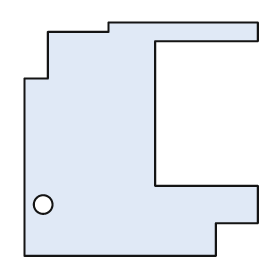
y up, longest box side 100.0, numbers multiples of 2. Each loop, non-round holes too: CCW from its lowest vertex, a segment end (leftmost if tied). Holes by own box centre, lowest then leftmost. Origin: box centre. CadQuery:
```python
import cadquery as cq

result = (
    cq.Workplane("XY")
    .moveTo(-50.0, -50.0)
    .lineTo(32.0, -50.0)
    .lineTo(32.0, -36.0)
    .lineTo(50.0, -36.0)
    .lineTo(50.0, -20.0)
    .lineTo(6.0, -20.0)
    .lineTo(6.0, 42.0)
    .lineTo(50.0, 42.0)
    .lineTo(50.0, 50.0)
    .lineTo(-14.0, 50.0)
    .lineTo(-14.0, 46.0)
    .lineTo(-40.0, 46.0)
    .lineTo(-40.0, 26.0)
    .lineTo(-50.0, 26.0)
    .close()
    .moveTo(-42.0, -28.0)
    .circle(4.0)
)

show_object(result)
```